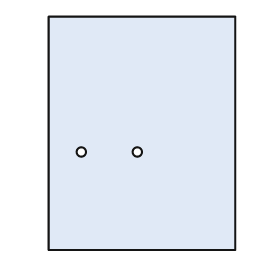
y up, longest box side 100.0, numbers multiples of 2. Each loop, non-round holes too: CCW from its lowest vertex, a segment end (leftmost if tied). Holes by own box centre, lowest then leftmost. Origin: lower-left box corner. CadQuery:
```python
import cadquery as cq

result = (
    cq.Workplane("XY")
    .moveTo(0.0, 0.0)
    .lineTo(80.0, 0.0)
    .lineTo(80.0, 100.0)
    .lineTo(0.0, 100.0)
    .close()
    .moveTo(14.0, 42.0)
    .circle(2.0)
    .moveTo(38.0, 42.0)
    .circle(2.0)
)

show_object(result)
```